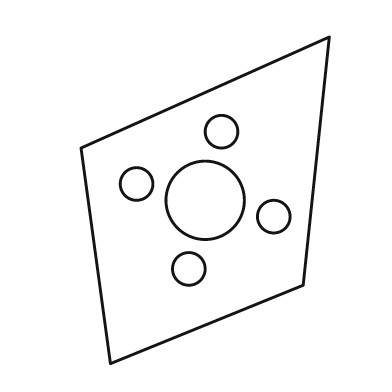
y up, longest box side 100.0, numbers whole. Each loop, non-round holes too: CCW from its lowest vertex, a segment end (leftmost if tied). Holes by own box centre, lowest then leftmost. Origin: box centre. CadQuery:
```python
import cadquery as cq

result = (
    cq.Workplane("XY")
    .moveTo(-29.0, -50.0)
    .lineTo(30.0, -26.0)
    .lineTo(38.0, 50.0)
    .lineTo(-38.0, 16.0)
    .close()
    .moveTo(-5.0, -21.0)
    .circle(5.0)
    .moveTo(21.0, -5.0)
    .circle(5.0)
    .moveTo(0.0, 0.0)
    .circle(12.0)
    .moveTo(-21.0, 5.0)
    .circle(5.0)
    .moveTo(5.0, 21.0)
    .circle(5.0)
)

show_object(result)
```